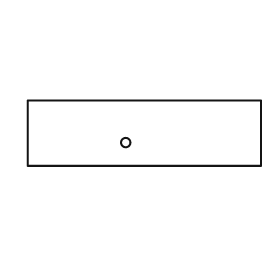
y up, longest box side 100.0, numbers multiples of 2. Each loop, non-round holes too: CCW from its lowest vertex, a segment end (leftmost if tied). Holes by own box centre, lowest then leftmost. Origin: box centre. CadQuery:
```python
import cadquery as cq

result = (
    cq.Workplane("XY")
    .moveTo(-50.0, -14.0)
    .lineTo(50.0, -14.0)
    .lineTo(50.0, 14.0)
    .lineTo(-50.0, 14.0)
    .close()
    .moveTo(-8.0, -4.0)
    .circle(2.0)
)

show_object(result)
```